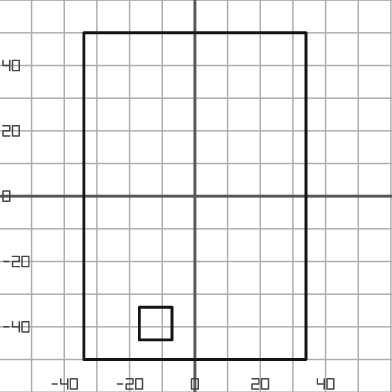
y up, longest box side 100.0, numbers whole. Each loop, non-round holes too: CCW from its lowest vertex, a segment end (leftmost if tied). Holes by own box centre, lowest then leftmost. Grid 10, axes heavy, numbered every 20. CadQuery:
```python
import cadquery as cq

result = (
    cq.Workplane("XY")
    .moveTo(-34.0, -50.0)
    .lineTo(34.0, -50.0)
    .lineTo(34.0, 50.0)
    .lineTo(-34.0, 50.0)
    .close()
    .moveTo(-17.0, -44.0)
    .lineTo(-7.0, -44.0)
    .lineTo(-7.0, -34.0)
    .lineTo(-17.0, -34.0)
    .close()
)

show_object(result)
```